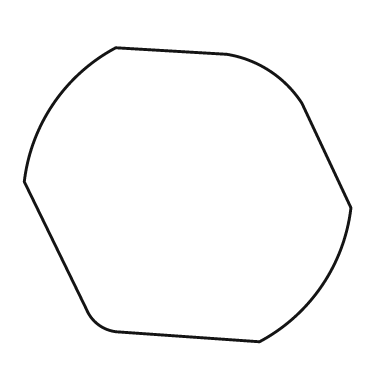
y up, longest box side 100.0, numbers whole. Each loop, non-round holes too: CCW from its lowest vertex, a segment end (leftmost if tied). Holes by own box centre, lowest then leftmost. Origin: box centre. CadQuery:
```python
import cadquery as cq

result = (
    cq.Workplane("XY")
    .moveTo(22.0, -45.0)
    .threePointArc((41.0, -28.0), (50.0, -4.0))
    .lineTo(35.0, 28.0)
    .threePointArc((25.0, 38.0), (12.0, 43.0))
    .lineTo(-22.0, 45.0)
    .threePointArc((-41.0, 28.0), (-50.0, 4.0))
    .lineTo(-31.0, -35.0)
    .threePointArc((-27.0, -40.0), (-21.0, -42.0))
    .close()
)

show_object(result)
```